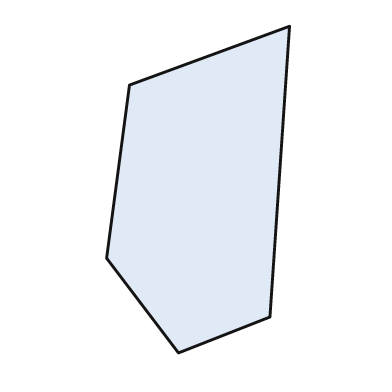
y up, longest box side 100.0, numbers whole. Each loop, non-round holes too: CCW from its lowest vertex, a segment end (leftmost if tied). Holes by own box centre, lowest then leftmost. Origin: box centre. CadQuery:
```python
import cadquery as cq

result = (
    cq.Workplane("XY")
    .moveTo(-6.0, -50.0)
    .lineTo(22.0, -39.0)
    .lineTo(28.0, 50.0)
    .lineTo(-21.0, 32.0)
    .lineTo(-28.0, -21.0)
    .close()
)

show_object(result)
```